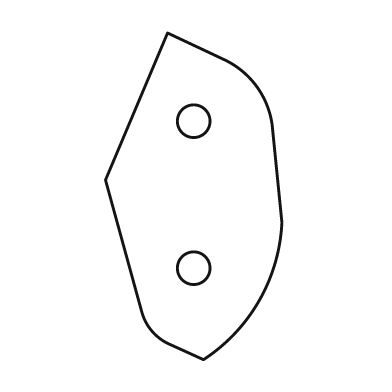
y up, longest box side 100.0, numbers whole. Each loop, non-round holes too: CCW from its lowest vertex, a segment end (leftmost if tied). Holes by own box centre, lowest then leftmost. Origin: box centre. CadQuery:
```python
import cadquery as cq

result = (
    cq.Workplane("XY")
    .moveTo(3.0, -50.0)
    .threePointArc((20.0, -32.0), (27.0, -8.0))
    .lineTo(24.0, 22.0)
    .threePointArc((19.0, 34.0), (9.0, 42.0))
    .lineTo(-8.0, 50.0)
    .lineTo(-27.0, 5.0)
    .lineTo(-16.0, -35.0)
    .threePointArc((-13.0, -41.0), (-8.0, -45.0))
    .close()
    .moveTo(0.0, -22.0)
    .circle(5.0)
    .moveTo(0.0, 23.0)
    .circle(5.0)
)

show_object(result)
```